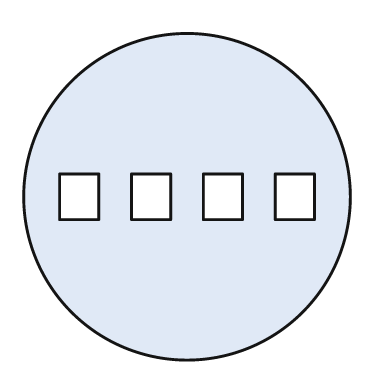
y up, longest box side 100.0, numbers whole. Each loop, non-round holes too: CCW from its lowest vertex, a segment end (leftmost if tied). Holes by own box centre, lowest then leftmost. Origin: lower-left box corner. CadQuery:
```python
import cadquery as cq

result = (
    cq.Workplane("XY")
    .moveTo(50.0, 50.0)
    .circle(50.0)
    .moveTo(11.0, 43.0)
    .lineTo(23.0, 43.0)
    .lineTo(23.0, 57.0)
    .lineTo(11.0, 57.0)
    .close()
    .moveTo(33.0, 43.0)
    .lineTo(45.0, 43.0)
    .lineTo(45.0, 57.0)
    .lineTo(33.0, 57.0)
    .close()
    .moveTo(55.0, 43.0)
    .lineTo(67.0, 43.0)
    .lineTo(67.0, 57.0)
    .lineTo(55.0, 57.0)
    .close()
    .moveTo(77.0, 43.0)
    .lineTo(89.0, 43.0)
    .lineTo(89.0, 57.0)
    .lineTo(77.0, 57.0)
    .close()
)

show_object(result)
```